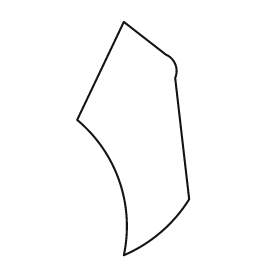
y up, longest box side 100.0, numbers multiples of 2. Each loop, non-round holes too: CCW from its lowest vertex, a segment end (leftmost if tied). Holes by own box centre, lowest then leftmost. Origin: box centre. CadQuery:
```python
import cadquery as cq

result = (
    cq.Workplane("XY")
    .moveTo(-4.0, -50.0)
    .threePointArc((12.0, -40.0), (24.0, -26.0))
    .lineTo(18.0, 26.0)
    .threePointArc((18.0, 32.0), (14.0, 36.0))
    .lineTo(-4.0, 50.0)
    .lineTo(-24.0, 8.0)
    .threePointArc((-6.0, -18.0), (-4.0, -50.0))
    .close()
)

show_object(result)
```